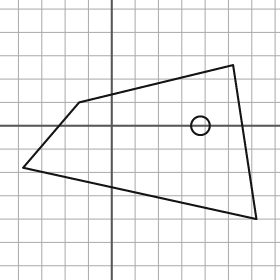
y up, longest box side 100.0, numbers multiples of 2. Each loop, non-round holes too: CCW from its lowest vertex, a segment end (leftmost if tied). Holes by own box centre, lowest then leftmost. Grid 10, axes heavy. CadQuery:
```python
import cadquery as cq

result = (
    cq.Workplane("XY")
    .moveTo(62.0, -40.0)
    .lineTo(52.0, 26.0)
    .lineTo(-14.0, 10.0)
    .lineTo(-38.0, -18.0)
    .close()
    .moveTo(38.0, 0.0)
    .circle(4.0)
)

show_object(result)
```